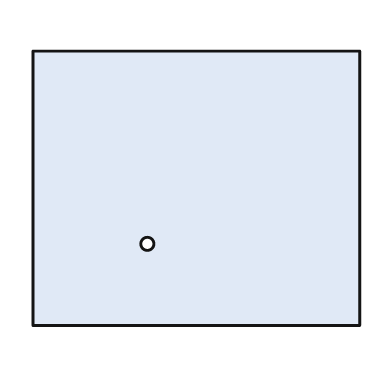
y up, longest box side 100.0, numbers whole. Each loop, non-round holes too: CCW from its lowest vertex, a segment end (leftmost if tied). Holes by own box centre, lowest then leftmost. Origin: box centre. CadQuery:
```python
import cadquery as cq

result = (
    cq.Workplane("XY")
    .moveTo(-50.0, -42.0)
    .lineTo(50.0, -42.0)
    .lineTo(50.0, 42.0)
    .lineTo(-50.0, 42.0)
    .close()
    .moveTo(-15.0, -17.0)
    .circle(2.0)
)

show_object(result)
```